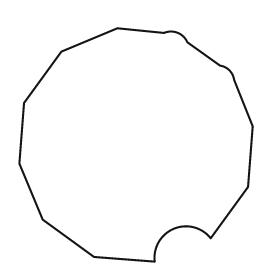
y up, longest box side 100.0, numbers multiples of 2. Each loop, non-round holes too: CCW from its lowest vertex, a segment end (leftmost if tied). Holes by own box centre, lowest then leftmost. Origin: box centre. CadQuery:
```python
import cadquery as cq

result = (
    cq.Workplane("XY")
    .moveTo(8.0, -50.0)
    .threePointArc((16.0, -36.0), (32.0, -40.0))
    .lineTo(48.0, -18.0)
    .lineTo(50.0, 8.0)
    .lineTo(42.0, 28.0)
    .threePointArc((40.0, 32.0), (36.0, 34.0))
    .lineTo(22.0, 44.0)
    .threePointArc((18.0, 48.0), (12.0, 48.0))
    .lineTo(-8.0, 50.0)
    .lineTo(-32.0, 40.0)
    .lineTo(-48.0, 18.0)
    .lineTo(-50.0, -8.0)
    .lineTo(-40.0, -32.0)
    .lineTo(-18.0, -48.0)
    .close()
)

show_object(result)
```